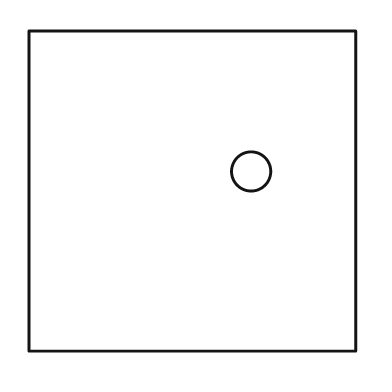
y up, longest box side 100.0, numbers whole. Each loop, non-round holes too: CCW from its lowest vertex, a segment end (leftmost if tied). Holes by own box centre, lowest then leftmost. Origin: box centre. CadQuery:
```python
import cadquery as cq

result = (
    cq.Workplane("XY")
    .moveTo(-50.0, -49.0)
    .lineTo(50.0, -49.0)
    .lineTo(50.0, 49.0)
    .lineTo(-50.0, 49.0)
    .close()
    .moveTo(18.0, 6.0)
    .circle(6.0)
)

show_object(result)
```